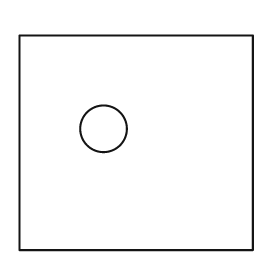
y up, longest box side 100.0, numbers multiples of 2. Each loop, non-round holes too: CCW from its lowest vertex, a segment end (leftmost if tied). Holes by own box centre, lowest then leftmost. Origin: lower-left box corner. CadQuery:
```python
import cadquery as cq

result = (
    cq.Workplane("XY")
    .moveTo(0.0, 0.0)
    .lineTo(100.0, 0.0)
    .lineTo(100.0, 92.0)
    .lineTo(0.0, 92.0)
    .close()
    .moveTo(36.0, 52.0)
    .circle(10.0)
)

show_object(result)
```